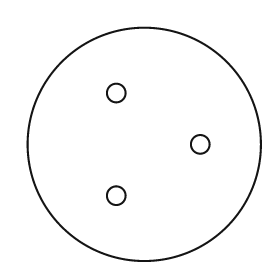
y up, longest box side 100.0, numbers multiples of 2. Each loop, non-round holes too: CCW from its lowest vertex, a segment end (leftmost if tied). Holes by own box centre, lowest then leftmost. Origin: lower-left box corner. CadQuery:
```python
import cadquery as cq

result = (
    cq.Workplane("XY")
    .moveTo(50.0, 50.0)
    .circle(50.0)
    .moveTo(38.0, 28.0)
    .circle(4.0)
    .moveTo(74.0, 50.0)
    .circle(4.0)
    .moveTo(38.0, 72.0)
    .circle(4.0)
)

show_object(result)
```